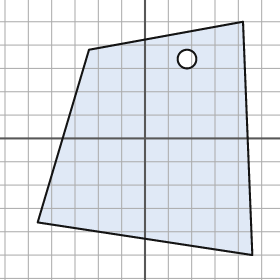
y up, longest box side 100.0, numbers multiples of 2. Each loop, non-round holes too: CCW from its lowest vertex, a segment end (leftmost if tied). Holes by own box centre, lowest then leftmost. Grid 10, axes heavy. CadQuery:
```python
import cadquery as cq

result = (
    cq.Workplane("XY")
    .moveTo(46.0, -50.0)
    .lineTo(42.0, 50.0)
    .lineTo(-24.0, 38.0)
    .lineTo(-46.0, -36.0)
    .close()
    .moveTo(18.0, 34.0)
    .circle(4.0)
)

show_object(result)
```